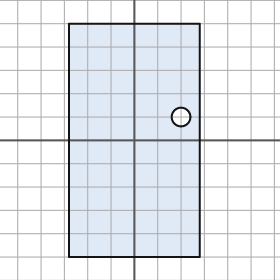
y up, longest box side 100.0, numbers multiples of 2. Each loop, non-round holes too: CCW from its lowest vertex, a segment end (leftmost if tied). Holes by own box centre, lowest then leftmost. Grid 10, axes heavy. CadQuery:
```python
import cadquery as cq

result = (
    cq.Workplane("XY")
    .moveTo(-28.0, -50.0)
    .lineTo(28.0, -50.0)
    .lineTo(28.0, 50.0)
    .lineTo(-28.0, 50.0)
    .close()
    .moveTo(20.0, 10.0)
    .circle(4.0)
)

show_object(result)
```